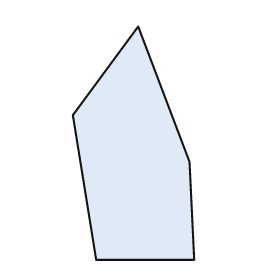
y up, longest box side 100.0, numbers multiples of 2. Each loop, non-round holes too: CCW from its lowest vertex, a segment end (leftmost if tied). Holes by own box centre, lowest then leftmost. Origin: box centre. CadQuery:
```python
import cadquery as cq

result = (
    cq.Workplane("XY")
    .moveTo(-16.0, -50.0)
    .lineTo(26.0, -50.0)
    .lineTo(24.0, -8.0)
    .lineTo(2.0, 50.0)
    .lineTo(-26.0, 12.0)
    .close()
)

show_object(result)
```